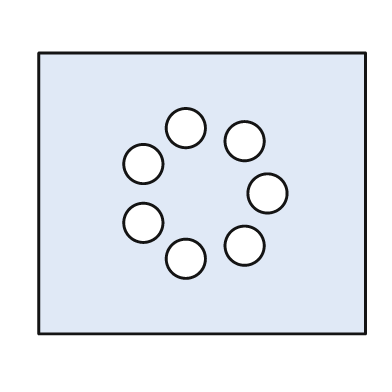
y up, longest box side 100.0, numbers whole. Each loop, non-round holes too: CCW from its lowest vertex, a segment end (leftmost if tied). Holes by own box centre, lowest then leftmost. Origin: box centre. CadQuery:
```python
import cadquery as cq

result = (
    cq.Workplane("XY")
    .moveTo(-50.0, -43.0)
    .lineTo(50.0, -43.0)
    .lineTo(50.0, 43.0)
    .lineTo(-50.0, 43.0)
    .close()
    .moveTo(-5.0, -20.0)
    .circle(6.0)
    .moveTo(13.0, -16.0)
    .circle(6.0)
    .moveTo(-18.0, -9.0)
    .circle(6.0)
    .moveTo(20.0, 0.0)
    .circle(6.0)
    .moveTo(-18.0, 9.0)
    .circle(6.0)
    .moveTo(13.0, 16.0)
    .circle(6.0)
    .moveTo(-5.0, 20.0)
    .circle(6.0)
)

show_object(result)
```